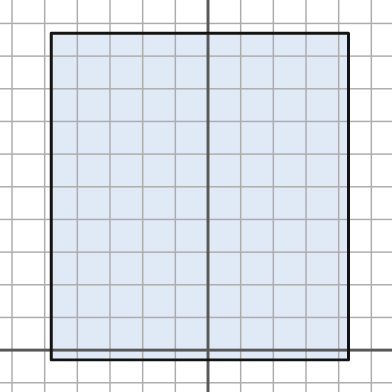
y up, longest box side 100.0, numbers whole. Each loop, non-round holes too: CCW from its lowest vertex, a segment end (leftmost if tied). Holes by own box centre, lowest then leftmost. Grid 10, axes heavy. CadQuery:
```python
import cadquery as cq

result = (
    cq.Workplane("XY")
    .moveTo(-48.0, -3.0)
    .lineTo(43.0, -3.0)
    .lineTo(43.0, 97.0)
    .lineTo(-48.0, 97.0)
    .close()
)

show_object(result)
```